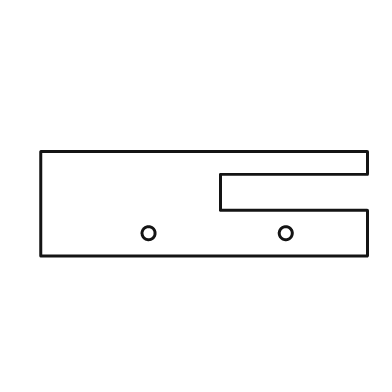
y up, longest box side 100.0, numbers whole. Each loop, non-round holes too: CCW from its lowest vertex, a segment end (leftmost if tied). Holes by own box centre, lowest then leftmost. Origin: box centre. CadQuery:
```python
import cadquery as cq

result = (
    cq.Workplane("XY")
    .moveTo(-50.0, -16.0)
    .lineTo(50.0, -16.0)
    .lineTo(50.0, -2.0)
    .lineTo(5.0, -2.0)
    .lineTo(5.0, 9.0)
    .lineTo(50.0, 9.0)
    .lineTo(50.0, 16.0)
    .lineTo(-50.0, 16.0)
    .close()
    .moveTo(-17.0, -9.0)
    .circle(2.0)
    .moveTo(25.0, -9.0)
    .circle(2.0)
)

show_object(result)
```